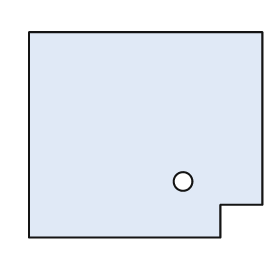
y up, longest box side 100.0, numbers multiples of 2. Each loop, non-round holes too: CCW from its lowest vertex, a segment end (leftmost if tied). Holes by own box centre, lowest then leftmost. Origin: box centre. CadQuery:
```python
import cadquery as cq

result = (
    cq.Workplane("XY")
    .moveTo(-50.0, -44.0)
    .lineTo(32.0, -44.0)
    .lineTo(32.0, -30.0)
    .lineTo(50.0, -30.0)
    .lineTo(50.0, 44.0)
    .lineTo(-50.0, 44.0)
    .close()
    .moveTo(16.0, -20.0)
    .circle(4.0)
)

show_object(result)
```